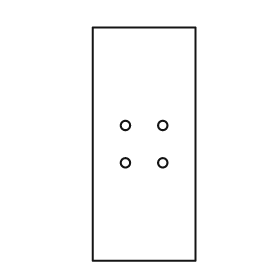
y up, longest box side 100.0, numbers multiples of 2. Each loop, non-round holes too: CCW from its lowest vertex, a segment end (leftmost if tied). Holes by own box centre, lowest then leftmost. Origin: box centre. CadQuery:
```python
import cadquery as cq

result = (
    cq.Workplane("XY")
    .moveTo(-22.0, -50.0)
    .lineTo(22.0, -50.0)
    .lineTo(22.0, 50.0)
    .lineTo(-22.0, 50.0)
    .close()
    .moveTo(-8.0, -8.0)
    .circle(2.0)
    .moveTo(8.0, -8.0)
    .circle(2.0)
    .moveTo(-8.0, 8.0)
    .circle(2.0)
    .moveTo(8.0, 8.0)
    .circle(2.0)
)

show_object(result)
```